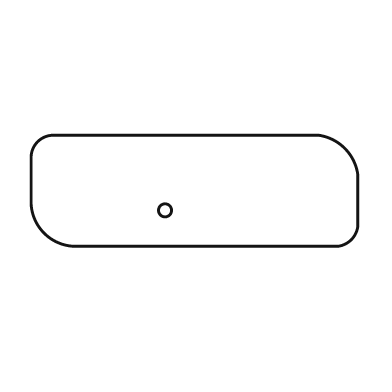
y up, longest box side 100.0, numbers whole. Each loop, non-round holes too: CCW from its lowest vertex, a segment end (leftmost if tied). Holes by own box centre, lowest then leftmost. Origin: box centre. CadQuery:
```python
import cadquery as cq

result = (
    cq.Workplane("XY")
    .moveTo(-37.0, -17.0)
    .lineTo(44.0, -17.0)
    .threePointArc((48.0, -15.0), (50.0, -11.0))
    .lineTo(50.0, 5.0)
    .threePointArc((46.0, 13.0), (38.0, 17.0))
    .lineTo(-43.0, 17.0)
    .threePointArc((-48.0, 15.0), (-50.0, 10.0))
    .lineTo(-50.0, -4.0)
    .threePointArc((-46.0, -13.0), (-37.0, -17.0))
    .close()
    .moveTo(-9.0, -6.0)
    .circle(2.0)
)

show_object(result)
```